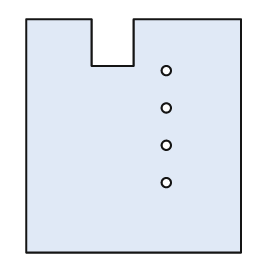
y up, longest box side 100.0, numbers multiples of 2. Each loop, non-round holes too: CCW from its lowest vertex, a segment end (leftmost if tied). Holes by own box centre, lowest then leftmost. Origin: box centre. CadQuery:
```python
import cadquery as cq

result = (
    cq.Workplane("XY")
    .moveTo(-46.0, -50.0)
    .lineTo(46.0, -50.0)
    .lineTo(46.0, 50.0)
    .lineTo(0.0, 50.0)
    .lineTo(0.0, 30.0)
    .lineTo(-18.0, 30.0)
    .lineTo(-18.0, 50.0)
    .lineTo(-46.0, 50.0)
    .close()
    .moveTo(14.0, -20.0)
    .circle(2.0)
    .moveTo(14.0, -4.0)
    .circle(2.0)
    .moveTo(14.0, 12.0)
    .circle(2.0)
    .moveTo(14.0, 28.0)
    .circle(2.0)
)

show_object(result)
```